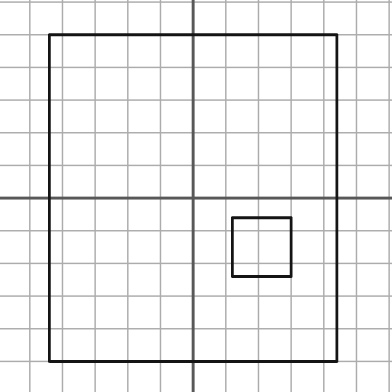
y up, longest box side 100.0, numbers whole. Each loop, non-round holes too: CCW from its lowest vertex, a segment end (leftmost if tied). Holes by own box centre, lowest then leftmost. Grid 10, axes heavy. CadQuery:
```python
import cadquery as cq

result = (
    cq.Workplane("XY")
    .moveTo(-44.0, -50.0)
    .lineTo(44.0, -50.0)
    .lineTo(44.0, 50.0)
    .lineTo(-44.0, 50.0)
    .close()
    .moveTo(12.0, -24.0)
    .lineTo(30.0, -24.0)
    .lineTo(30.0, -6.0)
    .lineTo(12.0, -6.0)
    .close()
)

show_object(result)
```